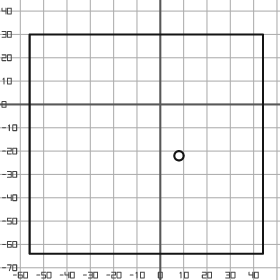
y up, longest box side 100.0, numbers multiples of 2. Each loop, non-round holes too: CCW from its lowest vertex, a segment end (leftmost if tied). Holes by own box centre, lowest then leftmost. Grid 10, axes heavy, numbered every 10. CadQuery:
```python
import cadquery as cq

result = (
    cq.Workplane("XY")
    .moveTo(-56.0, -64.0)
    .lineTo(44.0, -64.0)
    .lineTo(44.0, 30.0)
    .lineTo(-56.0, 30.0)
    .close()
    .moveTo(8.0, -22.0)
    .circle(2.0)
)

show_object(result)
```